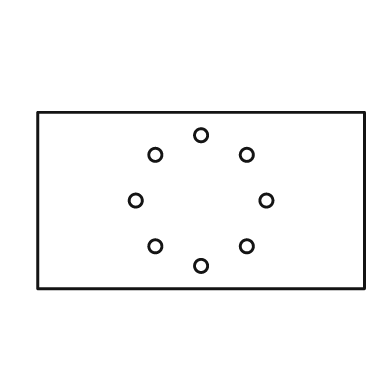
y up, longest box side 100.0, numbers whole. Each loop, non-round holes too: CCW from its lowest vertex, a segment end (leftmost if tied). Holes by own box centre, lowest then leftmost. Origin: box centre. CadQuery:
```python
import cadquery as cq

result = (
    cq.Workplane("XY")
    .moveTo(-50.0, -27.0)
    .lineTo(50.0, -27.0)
    .lineTo(50.0, 27.0)
    .lineTo(-50.0, 27.0)
    .close()
    .moveTo(0.0, -20.0)
    .circle(2.0)
    .moveTo(-14.0, -14.0)
    .circle(2.0)
    .moveTo(14.0, -14.0)
    .circle(2.0)
    .moveTo(-20.0, 0.0)
    .circle(2.0)
    .moveTo(20.0, 0.0)
    .circle(2.0)
    .moveTo(-14.0, 14.0)
    .circle(2.0)
    .moveTo(14.0, 14.0)
    .circle(2.0)
    .moveTo(0.0, 20.0)
    .circle(2.0)
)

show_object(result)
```